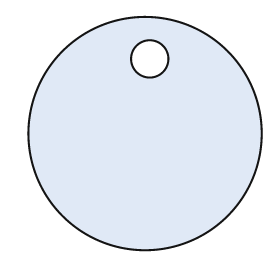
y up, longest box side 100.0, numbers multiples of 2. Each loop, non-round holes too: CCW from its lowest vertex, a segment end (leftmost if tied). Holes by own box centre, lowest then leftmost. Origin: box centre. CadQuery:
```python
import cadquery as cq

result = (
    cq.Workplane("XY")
    .moveTo(0.0, 0.0)
    .circle(50.0)
    .moveTo(2.0, 32.0)
    .circle(8.0)
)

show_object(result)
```